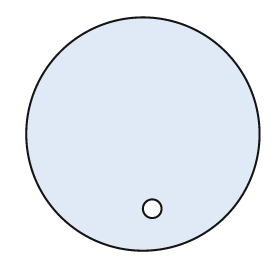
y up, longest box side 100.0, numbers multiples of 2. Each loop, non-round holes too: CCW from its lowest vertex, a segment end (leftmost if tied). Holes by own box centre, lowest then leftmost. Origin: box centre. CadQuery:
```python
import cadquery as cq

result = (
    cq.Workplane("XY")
    .moveTo(0.0, 0.0)
    .circle(50.0)
    .moveTo(4.0, -32.0)
    .circle(4.0)
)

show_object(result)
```